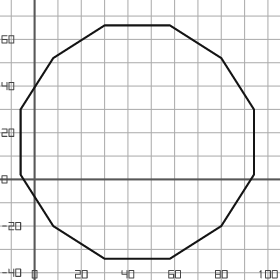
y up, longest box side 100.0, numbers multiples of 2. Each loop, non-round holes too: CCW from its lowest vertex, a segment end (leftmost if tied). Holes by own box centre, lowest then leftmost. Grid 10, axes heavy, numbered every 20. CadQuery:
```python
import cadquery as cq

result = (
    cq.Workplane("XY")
    .moveTo(30.0, -34.0)
    .lineTo(58.0, -34.0)
    .lineTo(80.0, -20.0)
    .lineTo(94.0, 2.0)
    .lineTo(94.0, 30.0)
    .lineTo(80.0, 52.0)
    .lineTo(58.0, 66.0)
    .lineTo(30.0, 66.0)
    .lineTo(8.0, 52.0)
    .lineTo(-6.0, 30.0)
    .lineTo(-6.0, 2.0)
    .lineTo(8.0, -20.0)
    .close()
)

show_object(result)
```